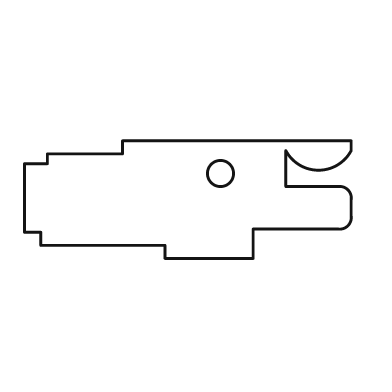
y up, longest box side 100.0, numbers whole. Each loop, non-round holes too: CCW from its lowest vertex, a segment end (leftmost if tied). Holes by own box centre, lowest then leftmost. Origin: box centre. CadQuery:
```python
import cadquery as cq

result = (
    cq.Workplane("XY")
    .moveTo(-7.0, -18.0)
    .lineTo(20.0, -18.0)
    .lineTo(20.0, -9.0)
    .lineTo(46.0, -9.0)
    .threePointArc((49.0, -8.0), (50.0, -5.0))
    .lineTo(50.0, 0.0)
    .threePointArc((49.0, 3.0), (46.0, 4.0))
    .lineTo(30.0, 4.0)
    .lineTo(30.0, 15.0)
    .threePointArc((40.0, 9.0), (50.0, 15.0))
    .lineTo(50.0, 18.0)
    .lineTo(-20.0, 18.0)
    .lineTo(-20.0, 14.0)
    .lineTo(-43.0, 14.0)
    .lineTo(-43.0, 11.0)
    .lineTo(-50.0, 11.0)
    .lineTo(-50.0, -10.0)
    .lineTo(-45.0, -10.0)
    .lineTo(-45.0, -14.0)
    .lineTo(-7.0, -14.0)
    .close()
    .moveTo(10.0, 8.0)
    .circle(4.0)
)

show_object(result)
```